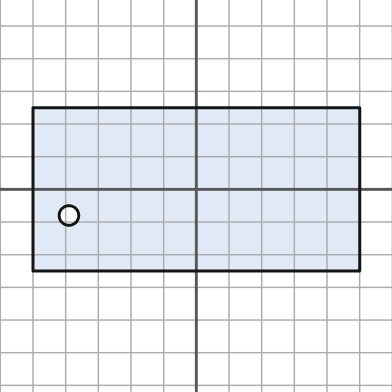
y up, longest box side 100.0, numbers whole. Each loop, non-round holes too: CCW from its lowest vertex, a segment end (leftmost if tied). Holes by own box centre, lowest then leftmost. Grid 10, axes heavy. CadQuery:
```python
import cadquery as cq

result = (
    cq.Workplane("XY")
    .moveTo(-50.0, -25.0)
    .lineTo(50.0, -25.0)
    .lineTo(50.0, 25.0)
    .lineTo(-50.0, 25.0)
    .close()
    .moveTo(-39.0, -8.0)
    .circle(3.0)
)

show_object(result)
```